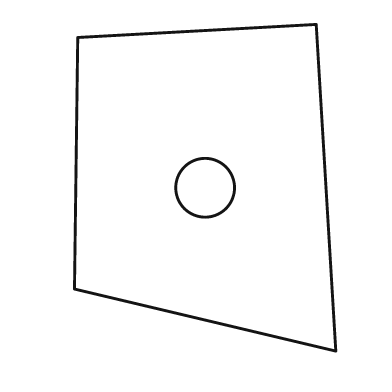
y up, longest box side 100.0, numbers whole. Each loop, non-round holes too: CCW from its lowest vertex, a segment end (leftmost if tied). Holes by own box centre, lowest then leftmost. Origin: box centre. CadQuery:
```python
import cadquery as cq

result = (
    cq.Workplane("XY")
    .moveTo(40.0, -50.0)
    .lineTo(34.0, 50.0)
    .lineTo(-39.0, 46.0)
    .lineTo(-40.0, -31.0)
    .close()
    .moveTo(0.0, 0.0)
    .circle(9.0)
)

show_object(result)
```